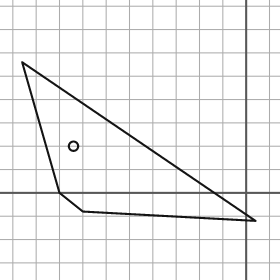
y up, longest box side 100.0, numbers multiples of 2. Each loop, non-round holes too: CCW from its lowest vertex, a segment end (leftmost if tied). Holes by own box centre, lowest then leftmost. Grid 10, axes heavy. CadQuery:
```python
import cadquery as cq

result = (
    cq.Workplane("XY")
    .moveTo(4.0, -12.0)
    .lineTo(-96.0, 56.0)
    .lineTo(-80.0, 0.0)
    .lineTo(-70.0, -8.0)
    .close()
    .moveTo(-74.0, 20.0)
    .circle(2.0)
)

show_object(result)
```